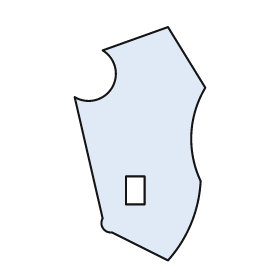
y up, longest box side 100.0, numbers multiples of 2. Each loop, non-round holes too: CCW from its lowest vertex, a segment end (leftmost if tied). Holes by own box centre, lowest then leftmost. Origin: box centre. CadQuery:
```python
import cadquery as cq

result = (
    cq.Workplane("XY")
    .moveTo(12.0, -50.0)
    .threePointArc((22.0, -34.0), (26.0, -16.0))
    .threePointArc((22.0, 4.0), (28.0, 24.0))
    .lineTo(12.0, 50.0)
    .lineTo(-16.0, 40.0)
    .threePointArc((-12.0, 24.0), (-28.0, 20.0))
    .lineTo(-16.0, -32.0)
    .threePointArc((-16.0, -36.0), (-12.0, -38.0))
    .close()
    .moveTo(-6.0, -26.0)
    .lineTo(2.0, -26.0)
    .lineTo(2.0, -14.0)
    .lineTo(-6.0, -14.0)
    .close()
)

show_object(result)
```